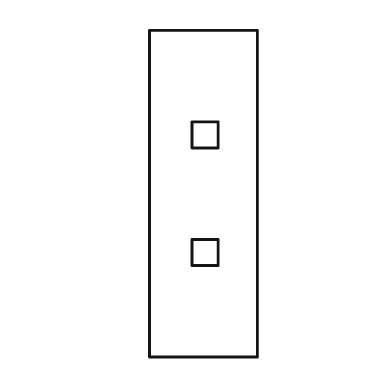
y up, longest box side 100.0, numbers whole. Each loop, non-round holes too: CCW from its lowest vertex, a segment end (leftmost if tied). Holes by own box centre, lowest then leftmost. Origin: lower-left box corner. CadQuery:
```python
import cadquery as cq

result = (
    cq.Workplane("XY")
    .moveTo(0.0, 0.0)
    .lineTo(33.0, 0.0)
    .lineTo(33.0, 100.0)
    .lineTo(0.0, 100.0)
    .close()
    .moveTo(13.0, 28.0)
    .lineTo(21.0, 28.0)
    .lineTo(21.0, 36.0)
    .lineTo(13.0, 36.0)
    .close()
    .moveTo(13.0, 64.0)
    .lineTo(21.0, 64.0)
    .lineTo(21.0, 72.0)
    .lineTo(13.0, 72.0)
    .close()
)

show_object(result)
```